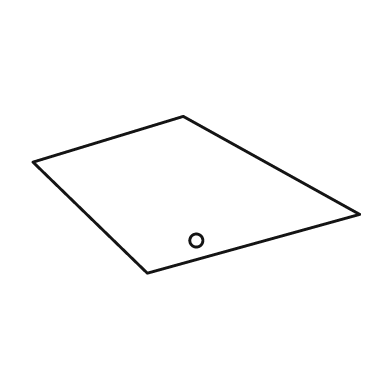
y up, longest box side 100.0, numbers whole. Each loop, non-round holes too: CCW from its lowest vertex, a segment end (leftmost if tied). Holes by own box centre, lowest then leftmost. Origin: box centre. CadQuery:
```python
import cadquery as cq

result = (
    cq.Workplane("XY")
    .moveTo(-15.0, -24.0)
    .lineTo(50.0, -6.0)
    .lineTo(-4.0, 24.0)
    .lineTo(-50.0, 10.0)
    .close()
    .moveTo(0.0, -14.0)
    .circle(2.0)
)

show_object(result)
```